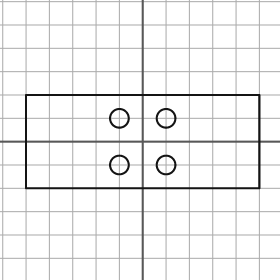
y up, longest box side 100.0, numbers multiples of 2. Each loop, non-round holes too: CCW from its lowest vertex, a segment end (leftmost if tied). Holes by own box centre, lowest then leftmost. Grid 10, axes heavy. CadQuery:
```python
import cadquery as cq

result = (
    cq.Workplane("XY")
    .moveTo(-50.0, -20.0)
    .lineTo(50.0, -20.0)
    .lineTo(50.0, 20.0)
    .lineTo(-50.0, 20.0)
    .close()
    .moveTo(-10.0, -10.0)
    .circle(4.0)
    .moveTo(10.0, -10.0)
    .circle(4.0)
    .moveTo(-10.0, 10.0)
    .circle(4.0)
    .moveTo(10.0, 10.0)
    .circle(4.0)
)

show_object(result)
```